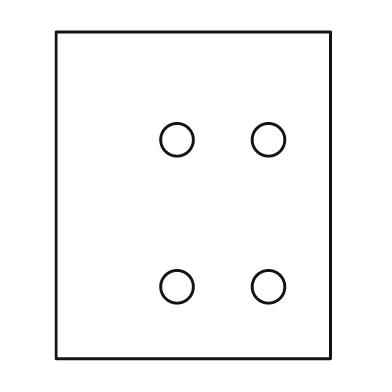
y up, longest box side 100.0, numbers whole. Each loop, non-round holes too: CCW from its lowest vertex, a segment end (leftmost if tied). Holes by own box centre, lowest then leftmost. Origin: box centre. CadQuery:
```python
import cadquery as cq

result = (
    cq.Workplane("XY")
    .moveTo(-42.0, -50.0)
    .lineTo(42.0, -50.0)
    .lineTo(42.0, 50.0)
    .lineTo(-42.0, 50.0)
    .close()
    .moveTo(-5.0, -28.0)
    .circle(5.0)
    .moveTo(23.0, -28.0)
    .circle(5.0)
    .moveTo(-5.0, 17.0)
    .circle(5.0)
    .moveTo(23.0, 17.0)
    .circle(5.0)
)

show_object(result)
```